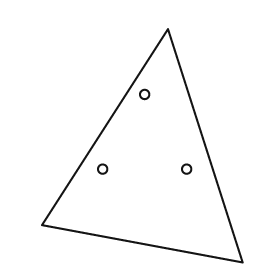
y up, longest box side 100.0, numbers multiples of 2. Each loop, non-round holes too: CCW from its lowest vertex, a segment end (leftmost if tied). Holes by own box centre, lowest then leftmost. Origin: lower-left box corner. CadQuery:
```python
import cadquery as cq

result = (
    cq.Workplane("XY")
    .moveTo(86.0, 0.0)
    .lineTo(54.0, 100.0)
    .lineTo(0.0, 16.0)
    .close()
    .moveTo(26.0, 40.0)
    .circle(2.0)
    .moveTo(62.0, 40.0)
    .circle(2.0)
    .moveTo(44.0, 72.0)
    .circle(2.0)
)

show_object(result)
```